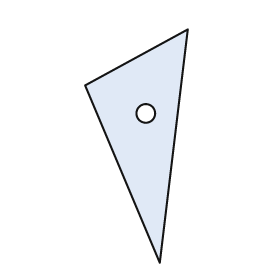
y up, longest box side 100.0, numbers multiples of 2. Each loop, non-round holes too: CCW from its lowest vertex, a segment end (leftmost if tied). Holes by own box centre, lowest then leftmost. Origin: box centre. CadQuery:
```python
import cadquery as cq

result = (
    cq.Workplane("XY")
    .moveTo(10.0, -50.0)
    .lineTo(22.0, 50.0)
    .lineTo(-22.0, 26.0)
    .close()
    .moveTo(4.0, 14.0)
    .circle(4.0)
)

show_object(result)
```